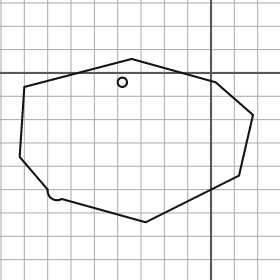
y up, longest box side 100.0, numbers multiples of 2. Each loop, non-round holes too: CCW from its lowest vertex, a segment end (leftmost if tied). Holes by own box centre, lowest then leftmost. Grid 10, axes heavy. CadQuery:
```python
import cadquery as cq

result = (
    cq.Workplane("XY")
    .moveTo(-28.0, -64.0)
    .lineTo(12.0, -44.0)
    .lineTo(18.0, -18.0)
    .lineTo(2.0, -4.0)
    .lineTo(-34.0, 6.0)
    .lineTo(-80.0, -6.0)
    .lineTo(-82.0, -36.0)
    .lineTo(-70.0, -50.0)
    .threePointArc((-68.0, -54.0), (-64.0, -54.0))
    .close()
    .moveTo(-38.0, -4.0)
    .circle(2.0)
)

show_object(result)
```